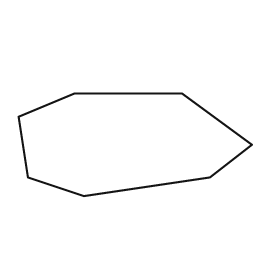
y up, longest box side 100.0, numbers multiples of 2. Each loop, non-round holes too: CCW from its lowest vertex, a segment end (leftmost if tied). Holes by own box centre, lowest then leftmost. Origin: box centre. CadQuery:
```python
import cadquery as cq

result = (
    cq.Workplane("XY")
    .moveTo(-22.0, -22.0)
    .lineTo(32.0, -14.0)
    .lineTo(50.0, 0.0)
    .lineTo(20.0, 22.0)
    .lineTo(-26.0, 22.0)
    .lineTo(-50.0, 12.0)
    .lineTo(-46.0, -14.0)
    .close()
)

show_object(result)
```